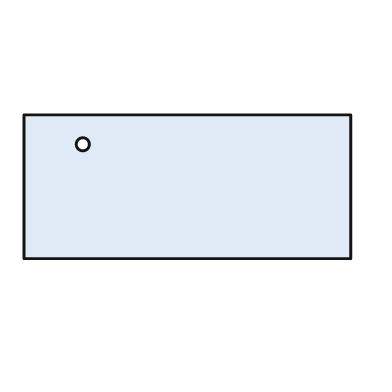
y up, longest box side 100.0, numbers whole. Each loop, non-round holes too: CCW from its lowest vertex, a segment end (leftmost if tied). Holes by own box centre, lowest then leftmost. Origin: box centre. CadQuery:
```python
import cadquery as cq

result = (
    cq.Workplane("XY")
    .moveTo(-50.0, -22.0)
    .lineTo(50.0, -22.0)
    .lineTo(50.0, 22.0)
    .lineTo(-50.0, 22.0)
    .close()
    .moveTo(-32.0, 13.0)
    .circle(2.0)
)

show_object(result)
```